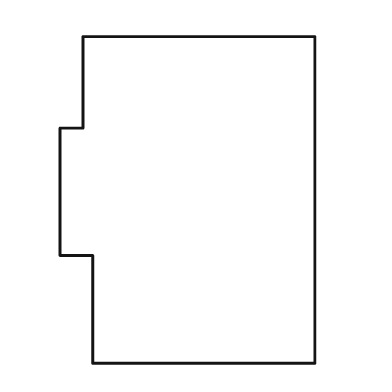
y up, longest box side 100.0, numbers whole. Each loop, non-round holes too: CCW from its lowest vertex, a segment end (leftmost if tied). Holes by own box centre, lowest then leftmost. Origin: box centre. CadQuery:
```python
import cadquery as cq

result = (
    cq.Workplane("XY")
    .moveTo(-29.0, -50.0)
    .lineTo(39.0, -50.0)
    .lineTo(39.0, 50.0)
    .lineTo(-32.0, 50.0)
    .lineTo(-32.0, 22.0)
    .lineTo(-39.0, 22.0)
    .lineTo(-39.0, -17.0)
    .lineTo(-29.0, -17.0)
    .close()
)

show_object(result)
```